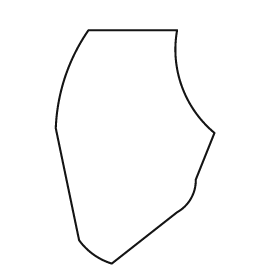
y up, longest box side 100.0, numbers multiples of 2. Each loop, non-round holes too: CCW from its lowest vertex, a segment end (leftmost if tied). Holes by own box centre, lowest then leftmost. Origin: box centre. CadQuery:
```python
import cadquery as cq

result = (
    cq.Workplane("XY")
    .moveTo(-10.0, -50.0)
    .lineTo(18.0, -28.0)
    .threePointArc((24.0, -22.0), (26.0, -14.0))
    .lineTo(34.0, 6.0)
    .threePointArc((20.0, 26.0), (18.0, 50.0))
    .lineTo(-20.0, 50.0)
    .threePointArc((-30.0, 30.0), (-34.0, 8.0))
    .lineTo(-24.0, -40.0)
    .threePointArc((-18.0, -46.0), (-10.0, -50.0))
    .close()
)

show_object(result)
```